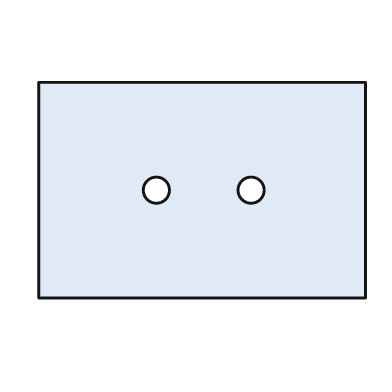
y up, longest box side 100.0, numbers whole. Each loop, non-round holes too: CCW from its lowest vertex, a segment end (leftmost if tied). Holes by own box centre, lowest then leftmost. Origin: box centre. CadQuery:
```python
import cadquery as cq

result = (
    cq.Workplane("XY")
    .moveTo(-50.0, -33.0)
    .lineTo(50.0, -33.0)
    .lineTo(50.0, 33.0)
    .lineTo(-50.0, 33.0)
    .close()
    .moveTo(-14.0, 0.0)
    .circle(4.0)
    .moveTo(15.0, 0.0)
    .circle(4.0)
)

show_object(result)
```